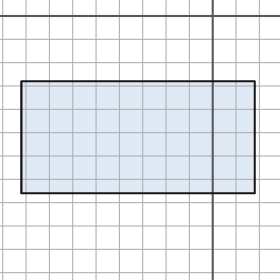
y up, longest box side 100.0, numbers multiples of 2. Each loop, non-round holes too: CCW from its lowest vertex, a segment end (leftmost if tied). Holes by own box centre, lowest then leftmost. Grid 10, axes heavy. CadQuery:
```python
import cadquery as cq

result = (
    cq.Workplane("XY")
    .moveTo(-82.0, -76.0)
    .lineTo(18.0, -76.0)
    .lineTo(18.0, -28.0)
    .lineTo(-82.0, -28.0)
    .close()
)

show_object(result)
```